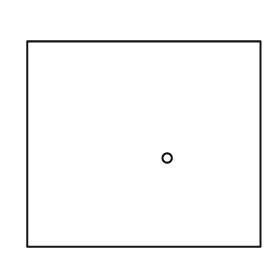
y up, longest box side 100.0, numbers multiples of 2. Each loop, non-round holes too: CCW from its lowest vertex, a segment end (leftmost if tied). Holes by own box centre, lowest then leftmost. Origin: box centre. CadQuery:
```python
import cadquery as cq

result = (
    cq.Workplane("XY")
    .moveTo(-50.0, -44.0)
    .lineTo(50.0, -44.0)
    .lineTo(50.0, 44.0)
    .lineTo(-50.0, 44.0)
    .close()
    .moveTo(10.0, -6.0)
    .circle(2.0)
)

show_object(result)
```